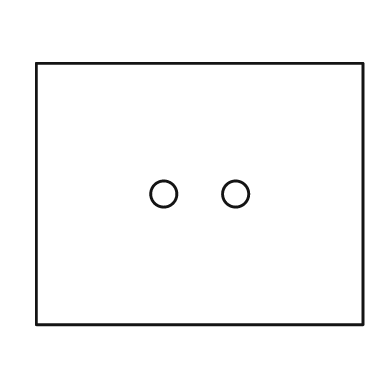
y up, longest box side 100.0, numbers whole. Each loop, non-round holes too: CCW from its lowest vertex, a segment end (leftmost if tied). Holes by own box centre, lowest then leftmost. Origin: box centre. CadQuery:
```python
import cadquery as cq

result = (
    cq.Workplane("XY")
    .moveTo(-50.0, -40.0)
    .lineTo(50.0, -40.0)
    .lineTo(50.0, 40.0)
    .lineTo(-50.0, 40.0)
    .close()
    .moveTo(-11.0, 0.0)
    .circle(4.0)
    .moveTo(11.0, 0.0)
    .circle(4.0)
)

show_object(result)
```